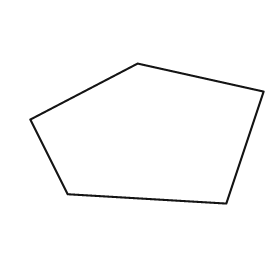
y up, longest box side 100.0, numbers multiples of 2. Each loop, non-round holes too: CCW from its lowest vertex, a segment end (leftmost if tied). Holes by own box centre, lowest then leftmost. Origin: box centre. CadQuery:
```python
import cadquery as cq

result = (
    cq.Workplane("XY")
    .moveTo(34.0, -30.0)
    .lineTo(50.0, 18.0)
    .lineTo(-4.0, 30.0)
    .lineTo(-50.0, 6.0)
    .lineTo(-34.0, -26.0)
    .close()
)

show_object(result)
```